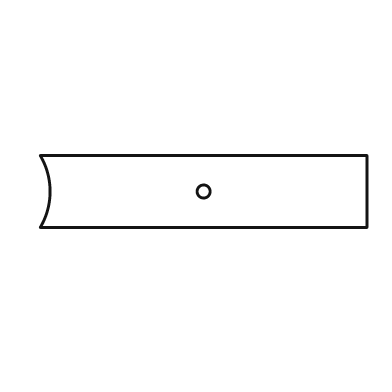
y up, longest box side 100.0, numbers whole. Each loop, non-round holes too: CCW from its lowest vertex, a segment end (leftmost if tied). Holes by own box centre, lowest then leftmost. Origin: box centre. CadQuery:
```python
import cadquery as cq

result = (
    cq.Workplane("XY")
    .moveTo(-50.0, -11.0)
    .lineTo(50.0, -11.0)
    .lineTo(50.0, 11.0)
    .lineTo(-50.0, 11.0)
    .threePointArc((-47.0, 0.0), (-50.0, -11.0))
    .close()
    .moveTo(0.0, 0.0)
    .circle(2.0)
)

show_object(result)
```